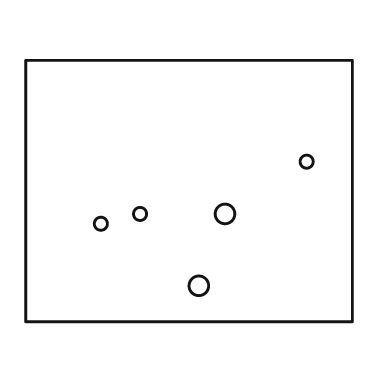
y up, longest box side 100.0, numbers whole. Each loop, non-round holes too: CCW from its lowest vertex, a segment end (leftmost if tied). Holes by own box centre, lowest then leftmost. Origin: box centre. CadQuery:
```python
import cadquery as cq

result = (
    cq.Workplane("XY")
    .moveTo(-50.0, -40.0)
    .lineTo(50.0, -40.0)
    .lineTo(50.0, 40.0)
    .lineTo(-50.0, 40.0)
    .close()
    .moveTo(3.0, -29.0)
    .circle(3.0)
    .moveTo(-27.0, -10.0)
    .circle(2.0)
    .moveTo(-15.0, -7.0)
    .circle(2.0)
    .moveTo(11.0, -7.0)
    .circle(3.0)
    .moveTo(36.0, 9.0)
    .circle(2.0)
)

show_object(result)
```